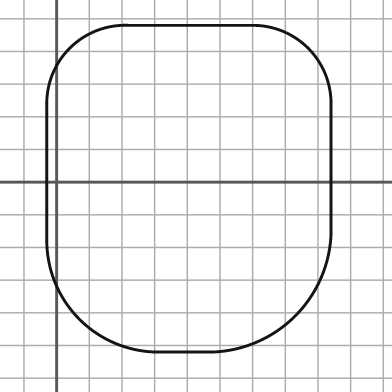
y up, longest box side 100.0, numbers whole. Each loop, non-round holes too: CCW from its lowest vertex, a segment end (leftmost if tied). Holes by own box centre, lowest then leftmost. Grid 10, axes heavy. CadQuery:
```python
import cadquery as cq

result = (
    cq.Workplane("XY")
    .moveTo(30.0, -52.0)
    .lineTo(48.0, -52.0)
    .threePointArc((73.0, -41.0), (84.0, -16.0))
    .lineTo(84.0, 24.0)
    .threePointArc((77.0, 41.0), (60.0, 48.0))
    .lineTo(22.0, 48.0)
    .threePointArc((4.0, 41.0), (-3.0, 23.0))
    .lineTo(-3.0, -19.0)
    .threePointArc((7.0, -42.0), (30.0, -52.0))
    .close()
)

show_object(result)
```